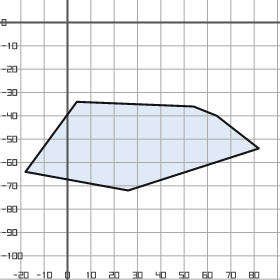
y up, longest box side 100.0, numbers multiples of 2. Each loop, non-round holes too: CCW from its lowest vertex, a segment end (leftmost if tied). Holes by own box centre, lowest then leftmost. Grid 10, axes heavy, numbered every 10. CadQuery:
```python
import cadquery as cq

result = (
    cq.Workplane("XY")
    .moveTo(26.0, -72.0)
    .lineTo(82.0, -54.0)
    .lineTo(64.0, -40.0)
    .lineTo(54.0, -36.0)
    .lineTo(4.0, -34.0)
    .lineTo(-18.0, -64.0)
    .close()
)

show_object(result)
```